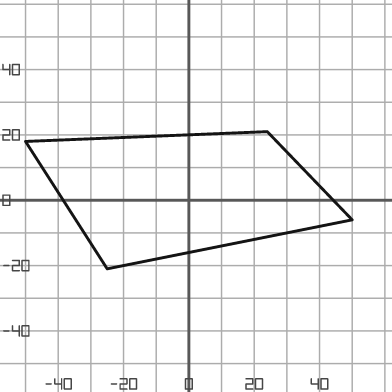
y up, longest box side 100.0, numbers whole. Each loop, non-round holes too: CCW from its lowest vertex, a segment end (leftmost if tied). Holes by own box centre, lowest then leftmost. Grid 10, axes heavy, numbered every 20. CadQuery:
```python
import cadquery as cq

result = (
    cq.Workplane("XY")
    .moveTo(-25.0, -21.0)
    .lineTo(50.0, -6.0)
    .lineTo(24.0, 21.0)
    .lineTo(-50.0, 18.0)
    .close()
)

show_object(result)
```